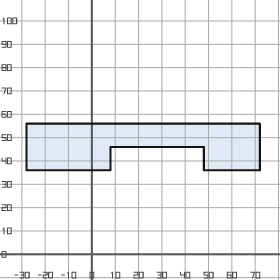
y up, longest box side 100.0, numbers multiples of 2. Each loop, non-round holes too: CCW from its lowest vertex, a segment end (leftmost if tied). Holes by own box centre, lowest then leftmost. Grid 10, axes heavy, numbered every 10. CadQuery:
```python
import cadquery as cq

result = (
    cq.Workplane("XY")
    .moveTo(-28.0, 36.0)
    .lineTo(8.0, 36.0)
    .lineTo(8.0, 46.0)
    .lineTo(48.0, 46.0)
    .lineTo(48.0, 36.0)
    .lineTo(72.0, 36.0)
    .lineTo(72.0, 56.0)
    .lineTo(-28.0, 56.0)
    .close()
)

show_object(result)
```